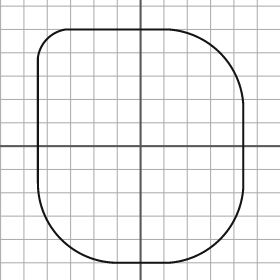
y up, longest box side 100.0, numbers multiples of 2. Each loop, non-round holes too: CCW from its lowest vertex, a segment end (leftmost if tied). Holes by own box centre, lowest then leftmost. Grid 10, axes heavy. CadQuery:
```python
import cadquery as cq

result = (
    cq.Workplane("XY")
    .moveTo(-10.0, -50.0)
    .lineTo(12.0, -50.0)
    .threePointArc((34.0, -40.0), (44.0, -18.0))
    .lineTo(44.0, 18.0)
    .threePointArc((34.0, 40.0), (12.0, 50.0))
    .lineTo(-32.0, 50.0)
    .threePointArc((-40.0, 46.0), (-44.0, 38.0))
    .lineTo(-44.0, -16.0)
    .threePointArc((-34.0, -40.0), (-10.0, -50.0))
    .close()
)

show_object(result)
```